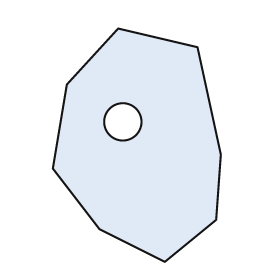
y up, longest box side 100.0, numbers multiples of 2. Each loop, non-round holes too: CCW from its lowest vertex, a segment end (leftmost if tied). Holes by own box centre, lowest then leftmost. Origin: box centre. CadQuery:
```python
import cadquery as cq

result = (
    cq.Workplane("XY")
    .moveTo(12.0, -50.0)
    .lineTo(34.0, -32.0)
    .lineTo(36.0, -4.0)
    .lineTo(26.0, 42.0)
    .lineTo(-8.0, 50.0)
    .lineTo(-30.0, 26.0)
    .lineTo(-36.0, -10.0)
    .lineTo(-16.0, -36.0)
    .close()
    .moveTo(-6.0, 10.0)
    .circle(8.0)
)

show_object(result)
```